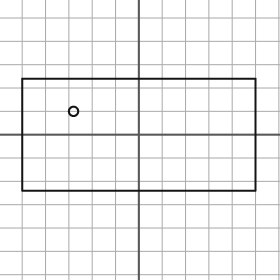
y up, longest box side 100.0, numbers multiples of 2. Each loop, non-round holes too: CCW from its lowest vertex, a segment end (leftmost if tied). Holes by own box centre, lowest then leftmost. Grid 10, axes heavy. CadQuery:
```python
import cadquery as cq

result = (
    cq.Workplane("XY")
    .moveTo(-50.0, -24.0)
    .lineTo(50.0, -24.0)
    .lineTo(50.0, 24.0)
    .lineTo(-50.0, 24.0)
    .close()
    .moveTo(-28.0, 10.0)
    .circle(2.0)
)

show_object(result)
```